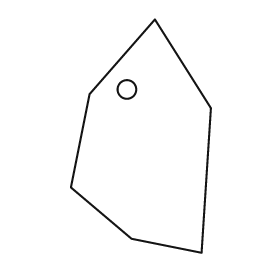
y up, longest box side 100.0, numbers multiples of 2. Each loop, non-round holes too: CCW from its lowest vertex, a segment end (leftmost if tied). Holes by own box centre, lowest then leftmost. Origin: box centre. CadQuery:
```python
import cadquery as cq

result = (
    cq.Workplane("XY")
    .moveTo(26.0, -50.0)
    .lineTo(30.0, 12.0)
    .lineTo(6.0, 50.0)
    .lineTo(-22.0, 18.0)
    .lineTo(-30.0, -22.0)
    .lineTo(-4.0, -44.0)
    .close()
    .moveTo(-6.0, 20.0)
    .circle(4.0)
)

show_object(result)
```